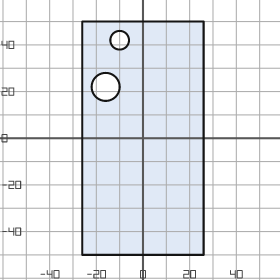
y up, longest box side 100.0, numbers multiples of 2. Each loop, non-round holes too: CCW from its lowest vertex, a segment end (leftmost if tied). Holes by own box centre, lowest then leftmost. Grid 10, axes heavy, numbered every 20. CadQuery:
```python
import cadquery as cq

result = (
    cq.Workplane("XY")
    .moveTo(-26.0, -50.0)
    .lineTo(26.0, -50.0)
    .lineTo(26.0, 50.0)
    .lineTo(-26.0, 50.0)
    .close()
    .moveTo(-16.0, 22.0)
    .circle(6.0)
    .moveTo(-10.0, 42.0)
    .circle(4.0)
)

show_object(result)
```